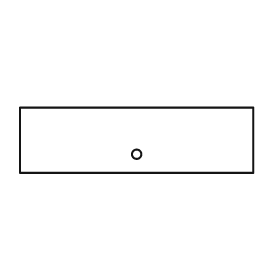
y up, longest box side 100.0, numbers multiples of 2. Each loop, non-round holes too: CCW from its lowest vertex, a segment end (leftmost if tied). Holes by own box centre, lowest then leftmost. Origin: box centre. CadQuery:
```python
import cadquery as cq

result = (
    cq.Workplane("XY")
    .moveTo(-50.0, -14.0)
    .lineTo(50.0, -14.0)
    .lineTo(50.0, 14.0)
    .lineTo(-50.0, 14.0)
    .close()
    .moveTo(0.0, -6.0)
    .circle(2.0)
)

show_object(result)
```